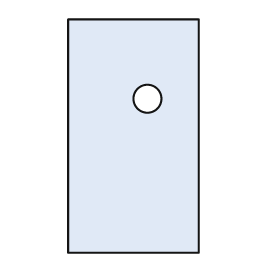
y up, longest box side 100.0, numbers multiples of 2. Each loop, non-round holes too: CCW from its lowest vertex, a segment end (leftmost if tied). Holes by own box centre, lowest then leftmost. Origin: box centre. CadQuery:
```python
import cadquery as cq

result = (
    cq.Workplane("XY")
    .moveTo(-28.0, -50.0)
    .lineTo(28.0, -50.0)
    .lineTo(28.0, 50.0)
    .lineTo(-28.0, 50.0)
    .close()
    .moveTo(6.0, 16.0)
    .circle(6.0)
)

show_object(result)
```